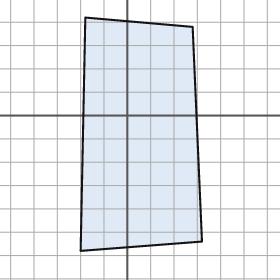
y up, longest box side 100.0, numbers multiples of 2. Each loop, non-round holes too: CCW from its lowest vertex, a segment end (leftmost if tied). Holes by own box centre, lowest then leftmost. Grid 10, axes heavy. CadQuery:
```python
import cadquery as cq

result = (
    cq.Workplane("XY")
    .moveTo(-20.0, -58.0)
    .lineTo(32.0, -54.0)
    .lineTo(28.0, 38.0)
    .lineTo(-18.0, 42.0)
    .close()
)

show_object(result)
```